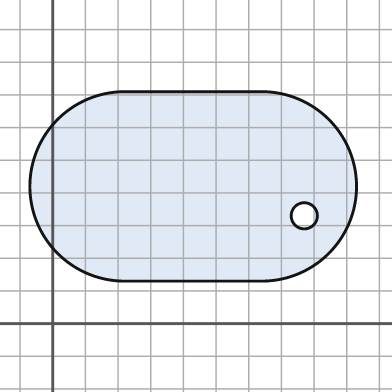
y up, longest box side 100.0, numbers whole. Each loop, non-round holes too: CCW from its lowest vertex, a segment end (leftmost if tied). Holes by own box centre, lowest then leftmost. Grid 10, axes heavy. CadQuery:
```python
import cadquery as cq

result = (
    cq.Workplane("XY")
    .moveTo(22.0, 13.0)
    .lineTo(64.0, 13.0)
    .threePointArc((93.0, 42.0), (64.0, 71.0))
    .lineTo(22.0, 71.0)
    .threePointArc((-7.0, 42.0), (22.0, 13.0))
    .close()
    .moveTo(77.0, 33.0)
    .circle(4.0)
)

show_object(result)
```